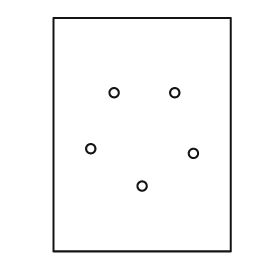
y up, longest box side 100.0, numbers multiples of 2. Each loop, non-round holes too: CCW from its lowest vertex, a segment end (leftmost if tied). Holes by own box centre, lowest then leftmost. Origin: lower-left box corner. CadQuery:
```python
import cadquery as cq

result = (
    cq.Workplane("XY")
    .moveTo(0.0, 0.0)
    .lineTo(76.0, 0.0)
    .lineTo(76.0, 100.0)
    .lineTo(0.0, 100.0)
    .close()
    .moveTo(38.0, 28.0)
    .circle(2.0)
    .moveTo(60.0, 42.0)
    .circle(2.0)
    .moveTo(16.0, 44.0)
    .circle(2.0)
    .moveTo(26.0, 68.0)
    .circle(2.0)
    .moveTo(52.0, 68.0)
    .circle(2.0)
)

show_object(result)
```